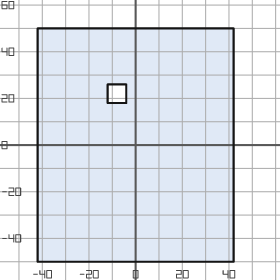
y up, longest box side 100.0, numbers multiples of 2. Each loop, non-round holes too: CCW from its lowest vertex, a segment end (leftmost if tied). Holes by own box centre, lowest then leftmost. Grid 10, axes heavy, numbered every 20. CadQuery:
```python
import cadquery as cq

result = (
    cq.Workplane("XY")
    .moveTo(-42.0, -50.0)
    .lineTo(42.0, -50.0)
    .lineTo(42.0, 50.0)
    .lineTo(-42.0, 50.0)
    .close()
    .moveTo(-12.0, 18.0)
    .lineTo(-4.0, 18.0)
    .lineTo(-4.0, 26.0)
    .lineTo(-12.0, 26.0)
    .close()
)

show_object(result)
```